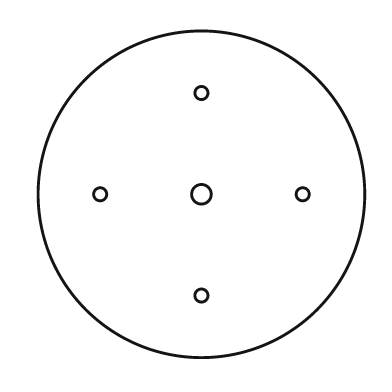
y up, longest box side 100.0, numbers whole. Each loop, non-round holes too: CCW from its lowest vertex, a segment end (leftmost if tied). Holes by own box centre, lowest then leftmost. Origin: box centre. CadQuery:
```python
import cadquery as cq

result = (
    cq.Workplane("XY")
    .moveTo(0.0, 0.0)
    .circle(50.0)
    .moveTo(0.0, -31.0)
    .circle(2.0)
    .moveTo(-31.0, 0.0)
    .circle(2.0)
    .moveTo(0.0, 0.0)
    .circle(3.0)
    .moveTo(31.0, 0.0)
    .circle(2.0)
    .moveTo(0.0, 31.0)
    .circle(2.0)
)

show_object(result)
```